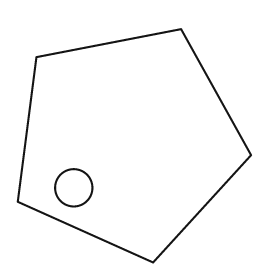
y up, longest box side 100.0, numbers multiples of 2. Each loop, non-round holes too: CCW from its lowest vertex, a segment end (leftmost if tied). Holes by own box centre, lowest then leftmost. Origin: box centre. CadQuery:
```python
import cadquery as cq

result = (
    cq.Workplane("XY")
    .moveTo(8.0, -50.0)
    .lineTo(50.0, -4.0)
    .lineTo(20.0, 50.0)
    .lineTo(-42.0, 38.0)
    .lineTo(-50.0, -24.0)
    .close()
    .moveTo(-26.0, -18.0)
    .circle(8.0)
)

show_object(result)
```